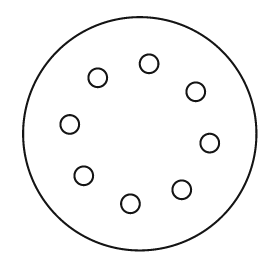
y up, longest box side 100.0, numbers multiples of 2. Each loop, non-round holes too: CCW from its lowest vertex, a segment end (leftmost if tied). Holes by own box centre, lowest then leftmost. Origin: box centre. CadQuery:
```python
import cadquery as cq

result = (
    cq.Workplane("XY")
    .moveTo(0.0, 0.0)
    .circle(50.0)
    .moveTo(-4.0, -30.0)
    .circle(4.0)
    .moveTo(18.0, -24.0)
    .circle(4.0)
    .moveTo(-24.0, -18.0)
    .circle(4.0)
    .moveTo(30.0, -4.0)
    .circle(4.0)
    .moveTo(-30.0, 4.0)
    .circle(4.0)
    .moveTo(24.0, 18.0)
    .circle(4.0)
    .moveTo(-18.0, 24.0)
    .circle(4.0)
    .moveTo(4.0, 30.0)
    .circle(4.0)
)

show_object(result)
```